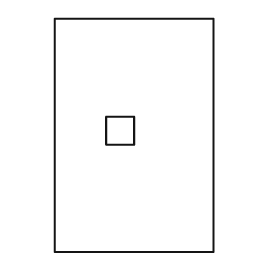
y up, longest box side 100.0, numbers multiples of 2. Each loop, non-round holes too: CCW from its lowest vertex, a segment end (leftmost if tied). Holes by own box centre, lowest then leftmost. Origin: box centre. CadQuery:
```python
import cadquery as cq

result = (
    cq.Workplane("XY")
    .moveTo(-34.0, -50.0)
    .lineTo(34.0, -50.0)
    .lineTo(34.0, 50.0)
    .lineTo(-34.0, 50.0)
    .close()
    .moveTo(-12.0, -4.0)
    .lineTo(0.0, -4.0)
    .lineTo(0.0, 8.0)
    .lineTo(-12.0, 8.0)
    .close()
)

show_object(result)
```